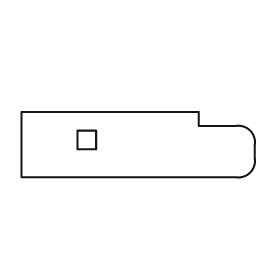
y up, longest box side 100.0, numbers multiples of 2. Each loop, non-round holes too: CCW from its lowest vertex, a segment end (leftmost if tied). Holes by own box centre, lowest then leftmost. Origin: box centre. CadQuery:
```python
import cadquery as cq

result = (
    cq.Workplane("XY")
    .moveTo(-50.0, -14.0)
    .lineTo(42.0, -14.0)
    .threePointArc((48.0, -12.0), (50.0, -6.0))
    .lineTo(50.0, 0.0)
    .threePointArc((48.0, 6.0), (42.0, 8.0))
    .lineTo(26.0, 8.0)
    .lineTo(26.0, 14.0)
    .lineTo(-50.0, 14.0)
    .close()
    .moveTo(-26.0, -2.0)
    .lineTo(-18.0, -2.0)
    .lineTo(-18.0, 6.0)
    .lineTo(-26.0, 6.0)
    .close()
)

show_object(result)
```